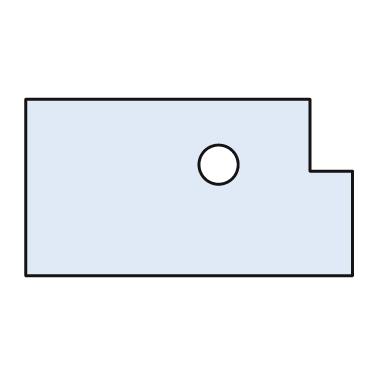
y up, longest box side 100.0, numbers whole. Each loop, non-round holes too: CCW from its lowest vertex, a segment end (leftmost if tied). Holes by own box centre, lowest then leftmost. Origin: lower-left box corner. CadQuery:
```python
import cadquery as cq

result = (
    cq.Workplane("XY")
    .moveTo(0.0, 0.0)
    .lineTo(100.0, 0.0)
    .lineTo(100.0, 32.0)
    .lineTo(87.0, 32.0)
    .lineTo(87.0, 54.0)
    .lineTo(0.0, 54.0)
    .close()
    .moveTo(59.0, 34.0)
    .circle(6.0)
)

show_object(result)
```